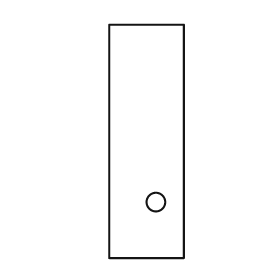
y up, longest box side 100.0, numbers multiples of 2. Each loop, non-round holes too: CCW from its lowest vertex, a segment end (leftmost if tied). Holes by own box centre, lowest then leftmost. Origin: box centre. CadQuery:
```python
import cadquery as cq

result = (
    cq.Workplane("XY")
    .moveTo(-16.0, -50.0)
    .lineTo(16.0, -50.0)
    .lineTo(16.0, 50.0)
    .lineTo(-16.0, 50.0)
    .close()
    .moveTo(4.0, -26.0)
    .circle(4.0)
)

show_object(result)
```